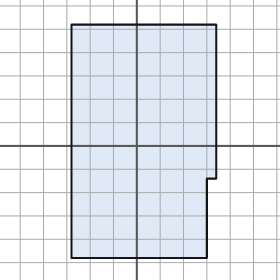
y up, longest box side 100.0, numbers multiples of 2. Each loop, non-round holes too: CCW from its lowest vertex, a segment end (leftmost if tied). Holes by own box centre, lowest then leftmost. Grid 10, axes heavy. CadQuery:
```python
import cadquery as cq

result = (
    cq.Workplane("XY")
    .moveTo(-28.0, -48.0)
    .lineTo(30.0, -48.0)
    .lineTo(30.0, -14.0)
    .lineTo(34.0, -14.0)
    .lineTo(34.0, 52.0)
    .lineTo(-28.0, 52.0)
    .close()
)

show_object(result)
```